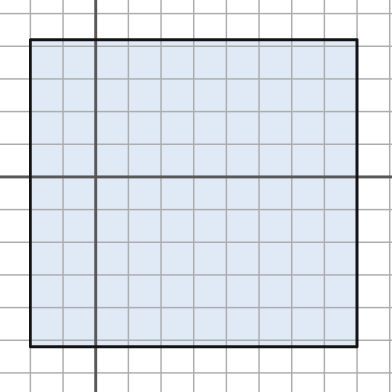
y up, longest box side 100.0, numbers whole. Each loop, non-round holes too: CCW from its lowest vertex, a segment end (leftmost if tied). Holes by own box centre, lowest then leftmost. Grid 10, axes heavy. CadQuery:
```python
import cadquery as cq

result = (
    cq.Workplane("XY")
    .moveTo(-20.0, -52.0)
    .lineTo(80.0, -52.0)
    .lineTo(80.0, 42.0)
    .lineTo(-20.0, 42.0)
    .close()
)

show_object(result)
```